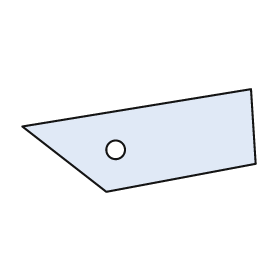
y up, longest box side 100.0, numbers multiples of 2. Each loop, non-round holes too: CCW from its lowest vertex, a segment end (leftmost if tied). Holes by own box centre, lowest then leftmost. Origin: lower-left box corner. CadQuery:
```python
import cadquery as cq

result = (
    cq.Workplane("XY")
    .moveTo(36.0, 0.0)
    .lineTo(100.0, 12.0)
    .lineTo(98.0, 44.0)
    .lineTo(0.0, 28.0)
    .close()
    .moveTo(40.0, 18.0)
    .circle(4.0)
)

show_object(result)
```